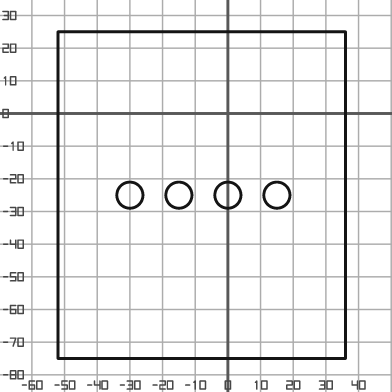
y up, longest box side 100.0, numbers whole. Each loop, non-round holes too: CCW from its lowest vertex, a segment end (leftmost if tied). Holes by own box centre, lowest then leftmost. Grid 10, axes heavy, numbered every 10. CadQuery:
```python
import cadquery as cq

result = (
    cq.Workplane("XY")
    .moveTo(-52.0, -75.0)
    .lineTo(36.0, -75.0)
    .lineTo(36.0, 25.0)
    .lineTo(-52.0, 25.0)
    .close()
    .moveTo(-30.0, -25.0)
    .circle(4.0)
    .moveTo(-15.0, -25.0)
    .circle(4.0)
    .moveTo(0.0, -25.0)
    .circle(4.0)
    .moveTo(15.0, -25.0)
    .circle(4.0)
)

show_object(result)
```